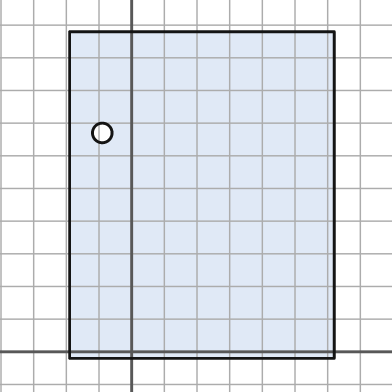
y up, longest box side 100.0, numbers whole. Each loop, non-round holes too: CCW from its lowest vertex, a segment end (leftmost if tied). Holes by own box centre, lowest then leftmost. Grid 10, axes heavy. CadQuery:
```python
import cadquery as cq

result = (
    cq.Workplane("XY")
    .moveTo(-19.0, -2.0)
    .lineTo(62.0, -2.0)
    .lineTo(62.0, 98.0)
    .lineTo(-19.0, 98.0)
    .close()
    .moveTo(-9.0, 67.0)
    .circle(3.0)
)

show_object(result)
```